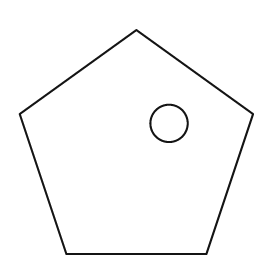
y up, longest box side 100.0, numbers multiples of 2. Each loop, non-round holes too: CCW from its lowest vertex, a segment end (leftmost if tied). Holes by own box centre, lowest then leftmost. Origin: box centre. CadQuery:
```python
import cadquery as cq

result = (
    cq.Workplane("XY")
    .moveTo(-30.0, -48.0)
    .lineTo(30.0, -48.0)
    .lineTo(50.0, 12.0)
    .lineTo(0.0, 48.0)
    .lineTo(-50.0, 12.0)
    .close()
    .moveTo(14.0, 8.0)
    .circle(8.0)
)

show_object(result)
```